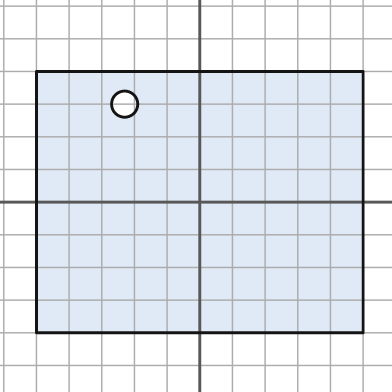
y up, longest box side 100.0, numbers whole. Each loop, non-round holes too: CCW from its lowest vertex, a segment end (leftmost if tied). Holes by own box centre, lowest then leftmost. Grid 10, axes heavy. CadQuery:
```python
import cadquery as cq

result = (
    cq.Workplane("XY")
    .moveTo(-50.0, -40.0)
    .lineTo(50.0, -40.0)
    .lineTo(50.0, 40.0)
    .lineTo(-50.0, 40.0)
    .close()
    .moveTo(-23.0, 30.0)
    .circle(4.0)
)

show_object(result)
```